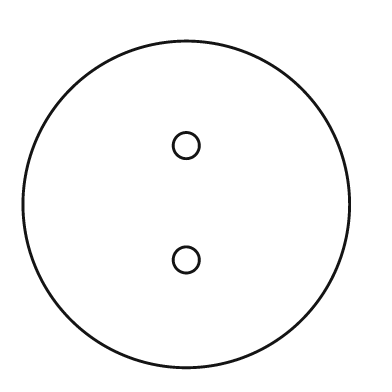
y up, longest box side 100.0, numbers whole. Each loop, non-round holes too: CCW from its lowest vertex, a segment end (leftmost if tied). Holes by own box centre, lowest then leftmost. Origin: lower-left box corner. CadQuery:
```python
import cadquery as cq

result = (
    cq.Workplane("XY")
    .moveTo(50.0, 50.0)
    .circle(50.0)
    .moveTo(50.0, 33.0)
    .circle(4.0)
    .moveTo(50.0, 68.0)
    .circle(4.0)
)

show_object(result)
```